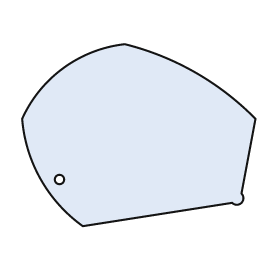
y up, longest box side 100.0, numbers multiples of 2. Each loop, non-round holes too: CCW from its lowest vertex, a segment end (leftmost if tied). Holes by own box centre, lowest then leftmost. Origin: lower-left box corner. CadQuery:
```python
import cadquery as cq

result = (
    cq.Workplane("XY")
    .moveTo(26.0, 0.0)
    .lineTo(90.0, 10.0)
    .threePointArc((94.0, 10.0), (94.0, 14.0))
    .lineTo(100.0, 46.0)
    .threePointArc((74.0, 66.0), (44.0, 78.0))
    .threePointArc((18.0, 68.0), (0.0, 46.0))
    .threePointArc((8.0, 20.0), (26.0, 0.0))
    .close()
    .moveTo(16.0, 20.0)
    .circle(2.0)
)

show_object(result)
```